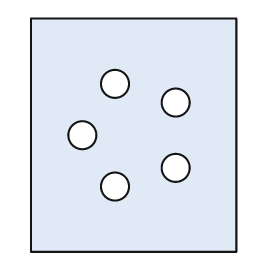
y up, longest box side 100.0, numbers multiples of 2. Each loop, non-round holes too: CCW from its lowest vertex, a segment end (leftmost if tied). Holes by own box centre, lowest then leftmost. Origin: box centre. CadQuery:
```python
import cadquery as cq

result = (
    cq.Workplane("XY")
    .moveTo(-44.0, -50.0)
    .lineTo(44.0, -50.0)
    .lineTo(44.0, 50.0)
    .lineTo(-44.0, 50.0)
    .close()
    .moveTo(-8.0, -22.0)
    .circle(6.0)
    .moveTo(18.0, -14.0)
    .circle(6.0)
    .moveTo(-22.0, 0.0)
    .circle(6.0)
    .moveTo(18.0, 14.0)
    .circle(6.0)
    .moveTo(-8.0, 22.0)
    .circle(6.0)
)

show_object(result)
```